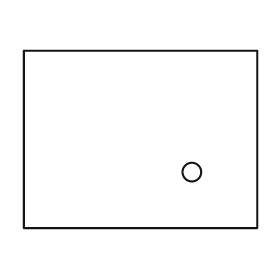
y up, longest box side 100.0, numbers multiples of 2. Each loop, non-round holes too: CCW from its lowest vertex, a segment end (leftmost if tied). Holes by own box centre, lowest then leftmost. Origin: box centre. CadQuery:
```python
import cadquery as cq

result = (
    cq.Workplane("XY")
    .moveTo(-50.0, -38.0)
    .lineTo(50.0, -38.0)
    .lineTo(50.0, 38.0)
    .lineTo(-50.0, 38.0)
    .close()
    .moveTo(22.0, -14.0)
    .circle(4.0)
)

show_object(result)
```